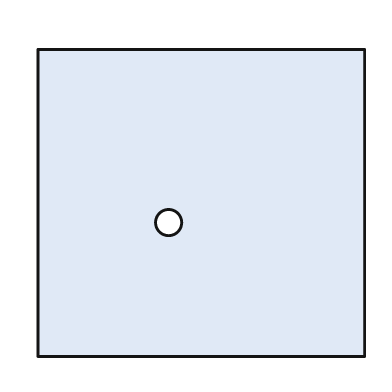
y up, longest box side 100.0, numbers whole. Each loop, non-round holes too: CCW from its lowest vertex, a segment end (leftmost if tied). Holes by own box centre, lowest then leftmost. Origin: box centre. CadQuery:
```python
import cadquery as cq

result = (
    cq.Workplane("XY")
    .moveTo(-50.0, -47.0)
    .lineTo(50.0, -47.0)
    .lineTo(50.0, 47.0)
    .lineTo(-50.0, 47.0)
    .close()
    .moveTo(-10.0, -6.0)
    .circle(4.0)
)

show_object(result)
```